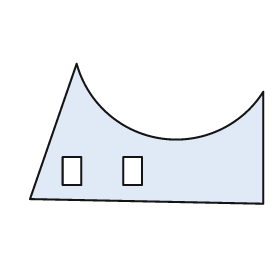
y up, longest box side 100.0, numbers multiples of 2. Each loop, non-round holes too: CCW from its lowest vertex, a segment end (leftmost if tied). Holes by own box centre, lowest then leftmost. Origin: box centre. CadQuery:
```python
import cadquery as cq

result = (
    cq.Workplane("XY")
    .moveTo(50.0, -30.0)
    .lineTo(50.0, 18.0)
    .threePointArc((6.0, -2.0), (-30.0, 30.0))
    .lineTo(-50.0, -28.0)
    .close()
    .moveTo(-36.0, -22.0)
    .lineTo(-28.0, -22.0)
    .lineTo(-28.0, -10.0)
    .lineTo(-36.0, -10.0)
    .close()
    .moveTo(-10.0, -22.0)
    .lineTo(-2.0, -22.0)
    .lineTo(-2.0, -10.0)
    .lineTo(-10.0, -10.0)
    .close()
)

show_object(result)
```